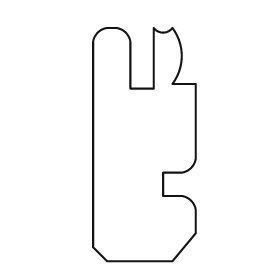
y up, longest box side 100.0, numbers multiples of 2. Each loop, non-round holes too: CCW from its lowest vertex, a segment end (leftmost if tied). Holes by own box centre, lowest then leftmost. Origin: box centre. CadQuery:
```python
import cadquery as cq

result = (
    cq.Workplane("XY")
    .moveTo(-16.0, -50.0)
    .lineTo(12.0, -50.0)
    .lineTo(22.0, -38.0)
    .lineTo(22.0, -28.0)
    .threePointArc((20.0, -24.0), (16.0, -22.0))
    .lineTo(8.0, -22.0)
    .lineTo(8.0, -12.0)
    .lineTo(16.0, -12.0)
    .threePointArc((20.0, -10.0), (22.0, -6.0))
    .lineTo(22.0, 26.0)
    .lineTo(12.0, 26.0)
    .threePointArc((16.0, 38.0), (12.0, 50.0))
    .threePointArc((8.0, 48.0), (4.0, 50.0))
    .lineTo(4.0, 24.0)
    .lineTo(-6.0, 24.0)
    .lineTo(-6.0, 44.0)
    .threePointArc((-8.0, 48.0), (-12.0, 50.0))
    .lineTo(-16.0, 50.0)
    .threePointArc((-20.0, 48.0), (-22.0, 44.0))
    .lineTo(-22.0, -44.0)
    .close()
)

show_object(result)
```